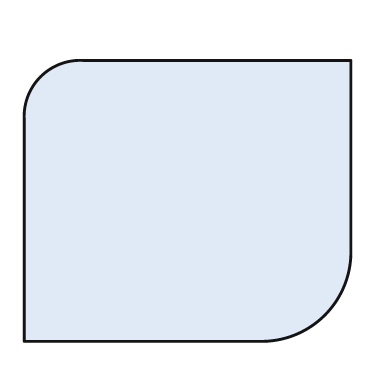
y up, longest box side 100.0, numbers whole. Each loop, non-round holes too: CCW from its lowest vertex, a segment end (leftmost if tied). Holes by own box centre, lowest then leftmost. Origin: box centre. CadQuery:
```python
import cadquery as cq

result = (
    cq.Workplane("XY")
    .moveTo(-50.0, -43.0)
    .lineTo(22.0, -43.0)
    .threePointArc((42.0, -35.0), (50.0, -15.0))
    .lineTo(50.0, 43.0)
    .lineTo(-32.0, 43.0)
    .threePointArc((-45.0, 38.0), (-50.0, 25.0))
    .close()
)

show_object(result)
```